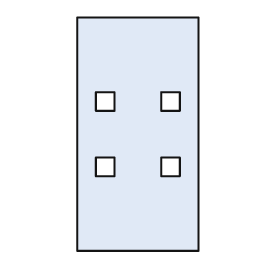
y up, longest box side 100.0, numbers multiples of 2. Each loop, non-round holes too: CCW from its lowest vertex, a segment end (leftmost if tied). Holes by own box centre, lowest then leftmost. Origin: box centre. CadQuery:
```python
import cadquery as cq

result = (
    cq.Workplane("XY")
    .moveTo(-26.0, -50.0)
    .lineTo(26.0, -50.0)
    .lineTo(26.0, 50.0)
    .lineTo(-26.0, 50.0)
    .close()
    .moveTo(-18.0, -18.0)
    .lineTo(-10.0, -18.0)
    .lineTo(-10.0, -10.0)
    .lineTo(-18.0, -10.0)
    .close()
    .moveTo(10.0, -18.0)
    .lineTo(18.0, -18.0)
    .lineTo(18.0, -10.0)
    .lineTo(10.0, -10.0)
    .close()
    .moveTo(-18.0, 10.0)
    .lineTo(-10.0, 10.0)
    .lineTo(-10.0, 18.0)
    .lineTo(-18.0, 18.0)
    .close()
    .moveTo(10.0, 10.0)
    .lineTo(18.0, 10.0)
    .lineTo(18.0, 18.0)
    .lineTo(10.0, 18.0)
    .close()
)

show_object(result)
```